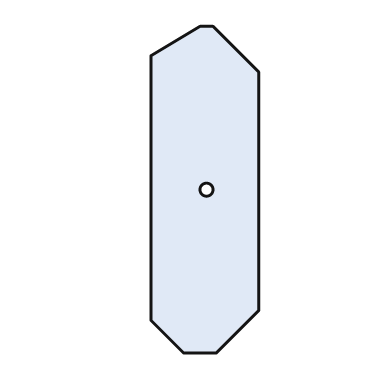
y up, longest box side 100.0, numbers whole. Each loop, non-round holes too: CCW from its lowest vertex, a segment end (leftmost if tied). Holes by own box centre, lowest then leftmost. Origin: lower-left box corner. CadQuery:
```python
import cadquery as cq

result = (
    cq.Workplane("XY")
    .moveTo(10.0, 0.0)
    .lineTo(20.0, 0.0)
    .lineTo(33.0, 13.0)
    .lineTo(33.0, 86.0)
    .lineTo(19.0, 100.0)
    .lineTo(15.0, 100.0)
    .lineTo(0.0, 91.0)
    .lineTo(0.0, 10.0)
    .close()
    .moveTo(17.0, 50.0)
    .circle(2.0)
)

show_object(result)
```